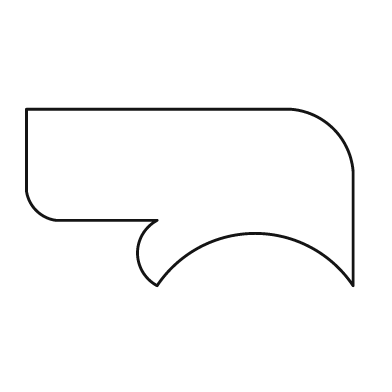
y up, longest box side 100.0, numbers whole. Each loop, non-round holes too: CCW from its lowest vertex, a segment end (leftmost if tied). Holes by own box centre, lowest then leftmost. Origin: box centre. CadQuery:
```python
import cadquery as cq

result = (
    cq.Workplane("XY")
    .moveTo(-10.0, -27.0)
    .threePointArc((20.0, -11.0), (50.0, -27.0))
    .lineTo(50.0, 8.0)
    .threePointArc((44.0, 21.0), (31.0, 27.0))
    .lineTo(-50.0, 27.0)
    .lineTo(-50.0, 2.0)
    .threePointArc((-47.0, -4.0), (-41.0, -7.0))
    .lineTo(-10.0, -7.0)
    .threePointArc((-16.0, -17.0), (-10.0, -27.0))
    .close()
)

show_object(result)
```